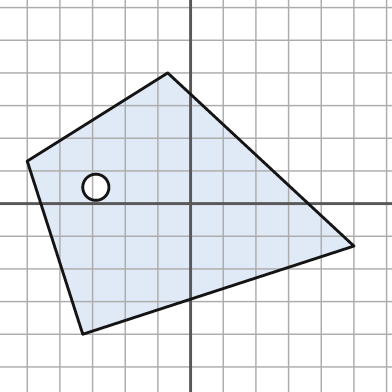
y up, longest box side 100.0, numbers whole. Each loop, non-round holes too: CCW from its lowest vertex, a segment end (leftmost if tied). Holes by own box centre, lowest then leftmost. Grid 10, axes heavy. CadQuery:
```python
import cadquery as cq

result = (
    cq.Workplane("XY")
    .moveTo(-33.0, -40.0)
    .lineTo(50.0, -13.0)
    .lineTo(-7.0, 40.0)
    .lineTo(-50.0, 13.0)
    .close()
    .moveTo(-29.0, 5.0)
    .circle(4.0)
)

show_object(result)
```